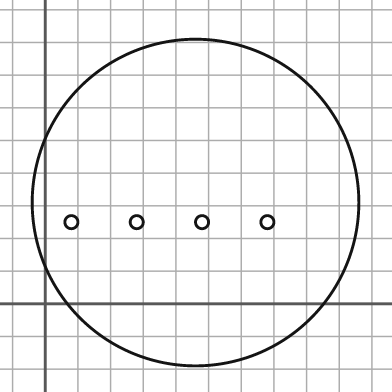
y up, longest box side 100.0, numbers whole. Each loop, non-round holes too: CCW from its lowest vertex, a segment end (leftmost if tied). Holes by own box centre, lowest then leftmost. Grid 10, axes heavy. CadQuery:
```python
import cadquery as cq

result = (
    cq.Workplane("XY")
    .moveTo(46.0, 31.0)
    .circle(50.0)
    .moveTo(8.0, 25.0)
    .circle(2.0)
    .moveTo(28.0, 25.0)
    .circle(2.0)
    .moveTo(48.0, 25.0)
    .circle(2.0)
    .moveTo(68.0, 25.0)
    .circle(2.0)
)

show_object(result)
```